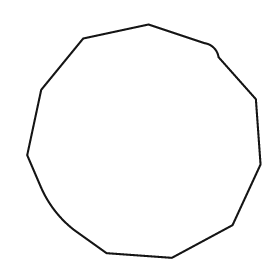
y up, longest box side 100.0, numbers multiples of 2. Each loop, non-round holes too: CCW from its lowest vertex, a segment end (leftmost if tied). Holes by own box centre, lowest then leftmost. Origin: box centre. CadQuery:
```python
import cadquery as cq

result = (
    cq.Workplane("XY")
    .moveTo(12.0, -50.0)
    .lineTo(38.0, -36.0)
    .lineTo(50.0, -10.0)
    .lineTo(48.0, 18.0)
    .lineTo(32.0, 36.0)
    .threePointArc((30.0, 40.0), (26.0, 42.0))
    .lineTo(2.0, 50.0)
    .lineTo(-26.0, 44.0)
    .lineTo(-44.0, 22.0)
    .lineTo(-50.0, -6.0)
    .lineTo(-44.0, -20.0)
    .threePointArc((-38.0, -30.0), (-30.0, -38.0))
    .lineTo(-16.0, -48.0)
    .close()
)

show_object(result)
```